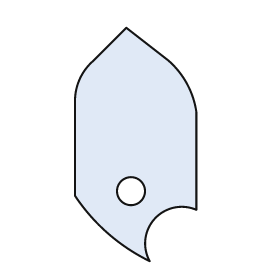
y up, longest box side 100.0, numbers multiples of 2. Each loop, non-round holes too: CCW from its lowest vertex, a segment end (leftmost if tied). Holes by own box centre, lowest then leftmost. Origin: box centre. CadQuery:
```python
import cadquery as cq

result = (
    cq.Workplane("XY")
    .moveTo(6.0, -50.0)
    .threePointArc((8.0, -32.0), (26.0, -28.0))
    .lineTo(26.0, 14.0)
    .threePointArc((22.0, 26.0), (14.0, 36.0))
    .lineTo(-4.0, 50.0)
    .lineTo(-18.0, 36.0)
    .threePointArc((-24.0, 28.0), (-26.0, 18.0))
    .lineTo(-26.0, -22.0)
    .threePointArc((-12.0, -38.0), (6.0, -50.0))
    .close()
    .moveTo(-2.0, -20.0)
    .circle(6.0)
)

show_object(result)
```